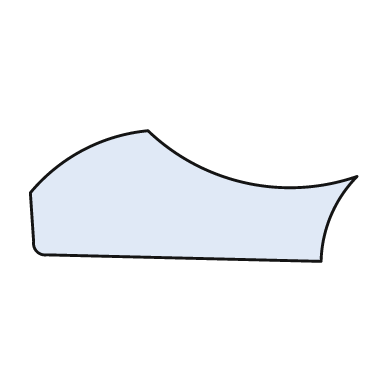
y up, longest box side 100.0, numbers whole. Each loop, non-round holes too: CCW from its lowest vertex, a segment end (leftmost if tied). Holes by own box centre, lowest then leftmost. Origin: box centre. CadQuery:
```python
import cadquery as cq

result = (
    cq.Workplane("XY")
    .moveTo(39.0, -20.0)
    .threePointArc((42.0, -6.0), (50.0, 6.0))
    .threePointArc((16.0, 4.0), (-14.0, 20.0))
    .threePointArc((-34.0, 14.0), (-50.0, 1.0))
    .lineTo(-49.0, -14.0)
    .threePointArc((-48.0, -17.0), (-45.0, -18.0))
    .close()
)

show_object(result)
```